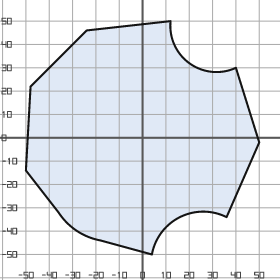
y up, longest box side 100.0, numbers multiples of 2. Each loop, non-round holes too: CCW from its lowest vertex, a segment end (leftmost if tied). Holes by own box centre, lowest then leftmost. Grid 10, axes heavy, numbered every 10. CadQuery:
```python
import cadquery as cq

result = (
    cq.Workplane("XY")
    .moveTo(4.0, -50.0)
    .threePointArc((16.0, -34.0), (36.0, -34.0))
    .lineTo(50.0, -2.0)
    .lineTo(40.0, 30.0)
    .threePointArc((20.0, 32.0), (12.0, 50.0))
    .lineTo(-24.0, 46.0)
    .lineTo(-48.0, 22.0)
    .lineTo(-50.0, -14.0)
    .lineTo(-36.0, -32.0)
    .threePointArc((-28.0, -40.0), (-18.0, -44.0))
    .close()
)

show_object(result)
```